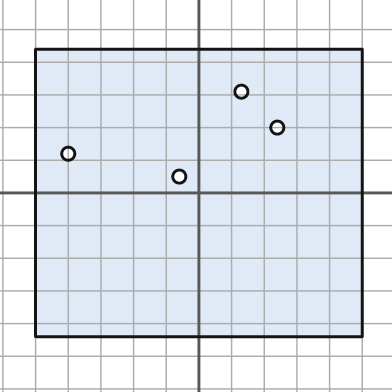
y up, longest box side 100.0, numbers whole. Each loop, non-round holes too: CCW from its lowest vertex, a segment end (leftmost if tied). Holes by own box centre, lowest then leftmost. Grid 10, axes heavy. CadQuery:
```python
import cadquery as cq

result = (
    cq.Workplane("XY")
    .moveTo(-50.0, -44.0)
    .lineTo(50.0, -44.0)
    .lineTo(50.0, 44.0)
    .lineTo(-50.0, 44.0)
    .close()
    .moveTo(-6.0, 5.0)
    .circle(2.0)
    .moveTo(-40.0, 12.0)
    .circle(2.0)
    .moveTo(24.0, 20.0)
    .circle(2.0)
    .moveTo(13.0, 31.0)
    .circle(2.0)
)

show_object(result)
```